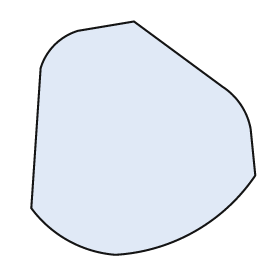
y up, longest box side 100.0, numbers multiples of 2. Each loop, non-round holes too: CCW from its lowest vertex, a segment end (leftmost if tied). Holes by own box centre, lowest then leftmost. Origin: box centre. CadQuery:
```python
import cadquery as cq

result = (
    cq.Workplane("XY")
    .moveTo(-12.0, -50.0)
    .threePointArc((22.0, -40.0), (48.0, -16.0))
    .lineTo(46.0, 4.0)
    .threePointArc((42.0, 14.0), (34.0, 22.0))
    .lineTo(-4.0, 50.0)
    .lineTo(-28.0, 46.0)
    .threePointArc((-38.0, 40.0), (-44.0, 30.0))
    .lineTo(-48.0, -30.0)
    .threePointArc((-32.0, -44.0), (-12.0, -50.0))
    .close()
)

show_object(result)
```